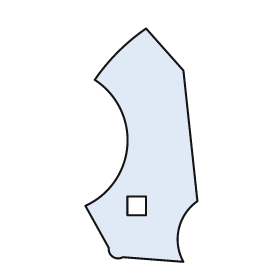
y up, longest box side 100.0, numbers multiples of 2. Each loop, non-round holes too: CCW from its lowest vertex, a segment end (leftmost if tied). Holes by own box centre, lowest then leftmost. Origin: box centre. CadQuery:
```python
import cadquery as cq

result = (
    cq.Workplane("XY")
    .moveTo(18.0, -50.0)
    .threePointArc((16.0, -36.0), (24.0, -24.0))
    .lineTo(18.0, 32.0)
    .lineTo(2.0, 50.0)
    .threePointArc((-10.0, 40.0), (-20.0, 28.0))
    .threePointArc((-6.0, 0.0), (-24.0, -26.0))
    .lineTo(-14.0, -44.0)
    .threePointArc((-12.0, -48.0), (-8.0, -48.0))
    .close()
    .moveTo(-6.0, -30.0)
    .lineTo(2.0, -30.0)
    .lineTo(2.0, -22.0)
    .lineTo(-6.0, -22.0)
    .close()
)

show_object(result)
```